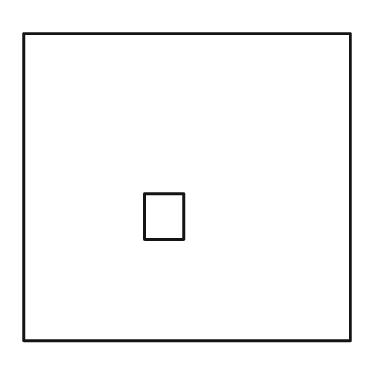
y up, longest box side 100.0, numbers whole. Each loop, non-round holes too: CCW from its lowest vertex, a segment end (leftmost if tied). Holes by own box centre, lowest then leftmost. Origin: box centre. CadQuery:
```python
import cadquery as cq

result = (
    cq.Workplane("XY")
    .moveTo(-50.0, -47.0)
    .lineTo(50.0, -47.0)
    .lineTo(50.0, 47.0)
    .lineTo(-50.0, 47.0)
    .close()
    .moveTo(-13.0, -16.0)
    .lineTo(-1.0, -16.0)
    .lineTo(-1.0, -2.0)
    .lineTo(-13.0, -2.0)
    .close()
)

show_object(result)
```